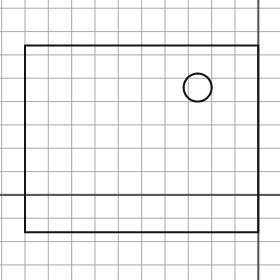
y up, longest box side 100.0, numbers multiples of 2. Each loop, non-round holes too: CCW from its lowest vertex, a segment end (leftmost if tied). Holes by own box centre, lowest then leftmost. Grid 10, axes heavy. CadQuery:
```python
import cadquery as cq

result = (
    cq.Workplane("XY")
    .moveTo(-100.0, -16.0)
    .lineTo(0.0, -16.0)
    .lineTo(0.0, 64.0)
    .lineTo(-100.0, 64.0)
    .close()
    .moveTo(-26.0, 46.0)
    .circle(6.0)
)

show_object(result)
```